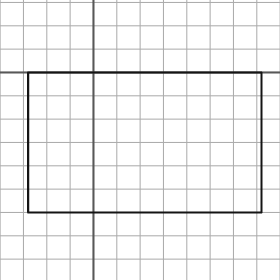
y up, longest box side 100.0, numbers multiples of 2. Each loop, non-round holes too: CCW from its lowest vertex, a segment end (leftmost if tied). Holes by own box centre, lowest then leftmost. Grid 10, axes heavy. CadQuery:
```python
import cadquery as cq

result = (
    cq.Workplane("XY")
    .moveTo(-28.0, -60.0)
    .lineTo(72.0, -60.0)
    .lineTo(72.0, 0.0)
    .lineTo(-28.0, 0.0)
    .close()
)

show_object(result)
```